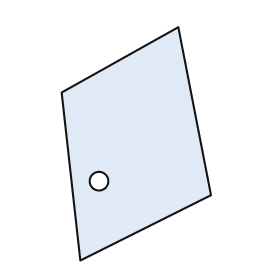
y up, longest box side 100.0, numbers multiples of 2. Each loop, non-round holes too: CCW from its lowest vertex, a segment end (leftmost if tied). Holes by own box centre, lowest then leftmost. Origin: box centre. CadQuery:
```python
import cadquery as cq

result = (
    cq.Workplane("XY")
    .moveTo(-24.0, -50.0)
    .lineTo(32.0, -22.0)
    .lineTo(18.0, 50.0)
    .lineTo(-32.0, 22.0)
    .close()
    .moveTo(-16.0, -16.0)
    .circle(4.0)
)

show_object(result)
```